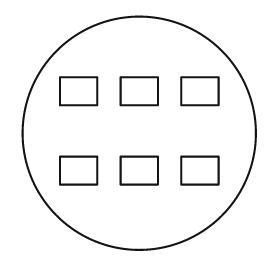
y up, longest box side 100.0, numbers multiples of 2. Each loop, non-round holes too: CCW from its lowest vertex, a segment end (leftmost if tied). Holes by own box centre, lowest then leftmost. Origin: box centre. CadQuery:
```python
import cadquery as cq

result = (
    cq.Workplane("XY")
    .moveTo(0.0, 0.0)
    .circle(50.0)
    .moveTo(-34.0, -22.0)
    .lineTo(-18.0, -22.0)
    .lineTo(-18.0, -10.0)
    .lineTo(-34.0, -10.0)
    .close()
    .moveTo(-8.0, -22.0)
    .lineTo(8.0, -22.0)
    .lineTo(8.0, -10.0)
    .lineTo(-8.0, -10.0)
    .close()
    .moveTo(18.0, -22.0)
    .lineTo(34.0, -22.0)
    .lineTo(34.0, -10.0)
    .lineTo(18.0, -10.0)
    .close()
    .moveTo(-34.0, 12.0)
    .lineTo(-18.0, 12.0)
    .lineTo(-18.0, 24.0)
    .lineTo(-34.0, 24.0)
    .close()
    .moveTo(-8.0, 12.0)
    .lineTo(8.0, 12.0)
    .lineTo(8.0, 24.0)
    .lineTo(-8.0, 24.0)
    .close()
    .moveTo(18.0, 12.0)
    .lineTo(34.0, 12.0)
    .lineTo(34.0, 24.0)
    .lineTo(18.0, 24.0)
    .close()
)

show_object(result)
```